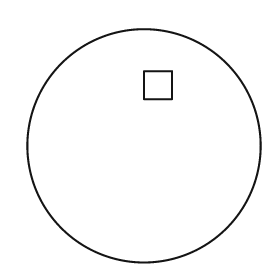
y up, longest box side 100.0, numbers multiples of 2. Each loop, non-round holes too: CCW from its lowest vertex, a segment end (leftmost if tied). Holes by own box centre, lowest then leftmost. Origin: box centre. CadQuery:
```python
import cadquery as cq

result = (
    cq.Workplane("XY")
    .moveTo(0.0, 0.0)
    .circle(50.0)
    .moveTo(0.0, 20.0)
    .lineTo(12.0, 20.0)
    .lineTo(12.0, 32.0)
    .lineTo(0.0, 32.0)
    .close()
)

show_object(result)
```